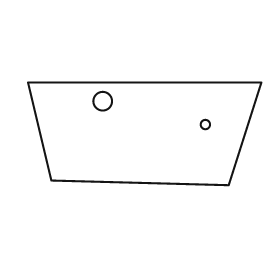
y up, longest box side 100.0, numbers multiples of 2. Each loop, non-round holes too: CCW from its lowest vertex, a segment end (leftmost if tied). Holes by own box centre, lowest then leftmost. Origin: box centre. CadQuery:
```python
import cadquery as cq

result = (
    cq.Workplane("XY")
    .moveTo(36.0, -22.0)
    .lineTo(50.0, 22.0)
    .lineTo(-50.0, 22.0)
    .lineTo(-40.0, -20.0)
    .close()
    .moveTo(26.0, 4.0)
    .circle(2.0)
    .moveTo(-18.0, 14.0)
    .circle(4.0)
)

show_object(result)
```